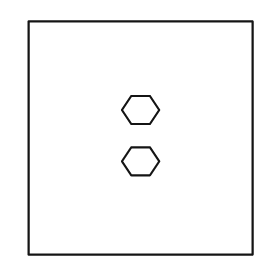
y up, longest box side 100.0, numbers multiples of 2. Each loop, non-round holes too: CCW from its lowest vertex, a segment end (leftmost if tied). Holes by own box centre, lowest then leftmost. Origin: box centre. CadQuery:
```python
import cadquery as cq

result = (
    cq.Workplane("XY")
    .moveTo(-48.0, -50.0)
    .lineTo(48.0, -50.0)
    .lineTo(48.0, 50.0)
    .lineTo(-48.0, 50.0)
    .close()
    .moveTo(-4.0, -16.0)
    .lineTo(4.0, -16.0)
    .lineTo(8.0, -10.0)
    .lineTo(4.0, -4.0)
    .lineTo(-4.0, -4.0)
    .lineTo(-8.0, -10.0)
    .close()
    .moveTo(-4.0, 6.0)
    .lineTo(4.0, 6.0)
    .lineTo(8.0, 12.0)
    .lineTo(4.0, 18.0)
    .lineTo(-4.0, 18.0)
    .lineTo(-8.0, 12.0)
    .close()
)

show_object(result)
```